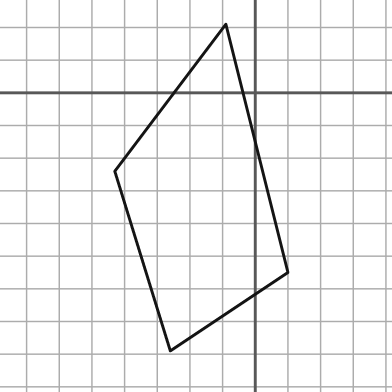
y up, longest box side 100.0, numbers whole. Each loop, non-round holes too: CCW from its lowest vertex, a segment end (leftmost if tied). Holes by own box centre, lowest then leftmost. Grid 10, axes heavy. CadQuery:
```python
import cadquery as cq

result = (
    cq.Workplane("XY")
    .moveTo(-26.0, -79.0)
    .lineTo(10.0, -55.0)
    .lineTo(-9.0, 21.0)
    .lineTo(-43.0, -24.0)
    .close()
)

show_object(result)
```